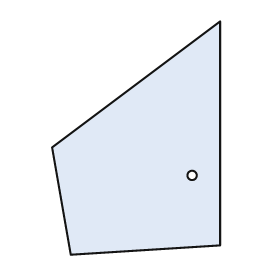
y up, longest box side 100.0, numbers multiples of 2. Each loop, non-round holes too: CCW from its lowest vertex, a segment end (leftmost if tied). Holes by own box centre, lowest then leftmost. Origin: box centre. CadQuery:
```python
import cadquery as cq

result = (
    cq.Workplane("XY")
    .moveTo(-28.0, -50.0)
    .lineTo(36.0, -46.0)
    .lineTo(36.0, 50.0)
    .lineTo(-36.0, -4.0)
    .close()
    .moveTo(24.0, -16.0)
    .circle(2.0)
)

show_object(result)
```